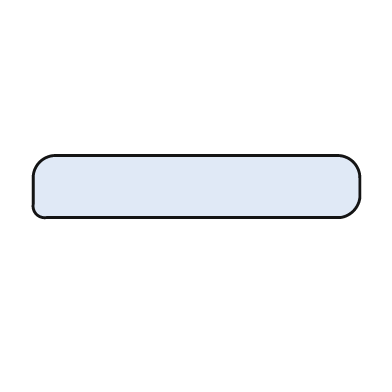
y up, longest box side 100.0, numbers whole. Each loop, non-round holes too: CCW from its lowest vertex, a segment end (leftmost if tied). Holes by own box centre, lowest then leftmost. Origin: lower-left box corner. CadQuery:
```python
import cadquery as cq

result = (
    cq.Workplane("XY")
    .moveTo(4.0, 0.0)
    .lineTo(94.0, 0.0)
    .threePointArc((98.0, 2.0), (100.0, 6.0))
    .lineTo(100.0, 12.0)
    .threePointArc((98.0, 17.0), (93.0, 19.0))
    .lineTo(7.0, 19.0)
    .threePointArc((2.0, 17.0), (0.0, 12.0))
    .lineTo(0.0, 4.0)
    .threePointArc((1.0, 1.0), (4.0, 0.0))
    .close()
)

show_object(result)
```